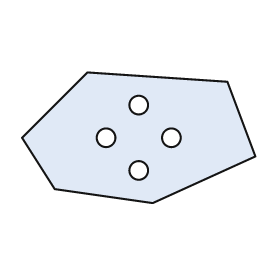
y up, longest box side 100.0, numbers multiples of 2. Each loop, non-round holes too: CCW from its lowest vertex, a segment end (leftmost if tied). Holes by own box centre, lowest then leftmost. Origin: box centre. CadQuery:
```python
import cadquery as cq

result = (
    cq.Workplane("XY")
    .moveTo(6.0, -28.0)
    .lineTo(50.0, -8.0)
    .lineTo(38.0, 24.0)
    .lineTo(-22.0, 28.0)
    .lineTo(-50.0, 0.0)
    .lineTo(-36.0, -22.0)
    .close()
    .moveTo(0.0, -14.0)
    .circle(4.0)
    .moveTo(-14.0, 0.0)
    .circle(4.0)
    .moveTo(14.0, 0.0)
    .circle(4.0)
    .moveTo(0.0, 14.0)
    .circle(4.0)
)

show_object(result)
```